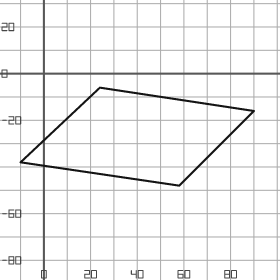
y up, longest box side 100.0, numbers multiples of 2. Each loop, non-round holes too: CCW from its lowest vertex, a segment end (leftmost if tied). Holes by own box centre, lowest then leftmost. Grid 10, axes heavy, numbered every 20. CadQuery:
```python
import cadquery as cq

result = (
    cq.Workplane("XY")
    .moveTo(58.0, -48.0)
    .lineTo(90.0, -16.0)
    .lineTo(24.0, -6.0)
    .lineTo(-10.0, -38.0)
    .close()
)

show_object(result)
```